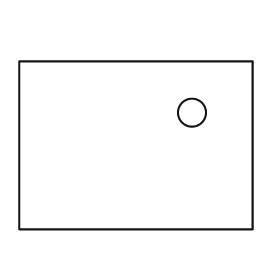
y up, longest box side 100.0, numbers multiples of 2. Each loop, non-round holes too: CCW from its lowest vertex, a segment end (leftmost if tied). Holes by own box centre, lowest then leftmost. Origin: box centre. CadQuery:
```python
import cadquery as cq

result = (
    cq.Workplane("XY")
    .moveTo(-50.0, -36.0)
    .lineTo(50.0, -36.0)
    .lineTo(50.0, 36.0)
    .lineTo(-50.0, 36.0)
    .close()
    .moveTo(24.0, 14.0)
    .circle(6.0)
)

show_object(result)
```